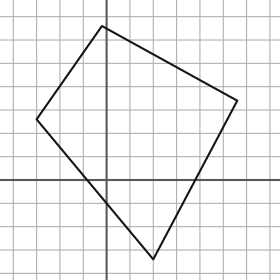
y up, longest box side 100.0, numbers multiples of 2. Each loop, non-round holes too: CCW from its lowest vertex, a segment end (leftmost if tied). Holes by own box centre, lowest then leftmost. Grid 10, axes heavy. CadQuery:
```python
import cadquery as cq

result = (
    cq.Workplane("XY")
    .moveTo(20.0, -34.0)
    .lineTo(56.0, 34.0)
    .lineTo(-2.0, 66.0)
    .lineTo(-30.0, 26.0)
    .close()
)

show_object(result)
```